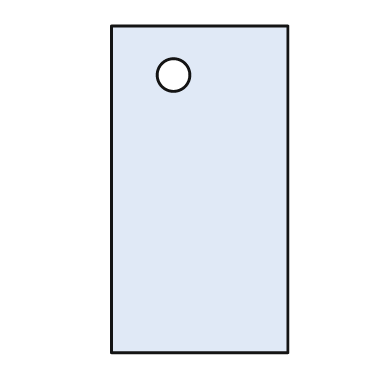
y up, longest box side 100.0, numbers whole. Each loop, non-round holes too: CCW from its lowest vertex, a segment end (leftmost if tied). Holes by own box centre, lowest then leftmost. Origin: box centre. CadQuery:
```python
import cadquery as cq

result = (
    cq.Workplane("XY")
    .moveTo(-27.0, -50.0)
    .lineTo(27.0, -50.0)
    .lineTo(27.0, 50.0)
    .lineTo(-27.0, 50.0)
    .close()
    .moveTo(-8.0, 35.0)
    .circle(5.0)
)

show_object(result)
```